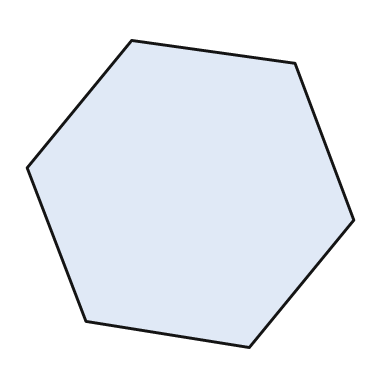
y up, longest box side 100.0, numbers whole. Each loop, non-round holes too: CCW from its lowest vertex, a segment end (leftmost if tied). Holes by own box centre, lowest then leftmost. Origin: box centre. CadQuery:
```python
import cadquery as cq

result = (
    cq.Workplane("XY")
    .moveTo(18.0, -47.0)
    .lineTo(50.0, -8.0)
    .lineTo(32.0, 40.0)
    .lineTo(-18.0, 47.0)
    .lineTo(-50.0, 8.0)
    .lineTo(-32.0, -39.0)
    .close()
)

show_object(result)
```